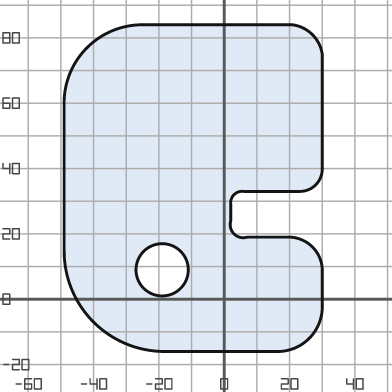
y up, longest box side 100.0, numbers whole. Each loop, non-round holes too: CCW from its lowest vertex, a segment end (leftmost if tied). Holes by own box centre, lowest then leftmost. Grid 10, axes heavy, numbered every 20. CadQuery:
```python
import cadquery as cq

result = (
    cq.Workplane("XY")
    .moveTo(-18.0, -16.0)
    .lineTo(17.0, -16.0)
    .threePointArc((26.0, -12.0), (30.0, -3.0))
    .lineTo(30.0, 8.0)
    .threePointArc((27.0, 16.0), (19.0, 19.0))
    .lineTo(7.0, 19.0)
    .threePointArc((3.0, 20.0), (2.0, 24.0))
    .lineTo(2.0, 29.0)
    .threePointArc((3.0, 32.0), (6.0, 33.0))
    .lineTo(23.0, 33.0)
    .threePointArc((28.0, 35.0), (30.0, 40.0))
    .lineTo(30.0, 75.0)
    .threePointArc((27.0, 81.0), (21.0, 84.0))
    .lineTo(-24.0, 84.0)
    .threePointArc((-42.0, 77.0), (-49.0, 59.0))
    .lineTo(-49.0, 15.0)
    .threePointArc((-40.0, -7.0), (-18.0, -16.0))
    .close()
    .moveTo(-19.0, 9.0)
    .circle(8.0)
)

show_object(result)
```